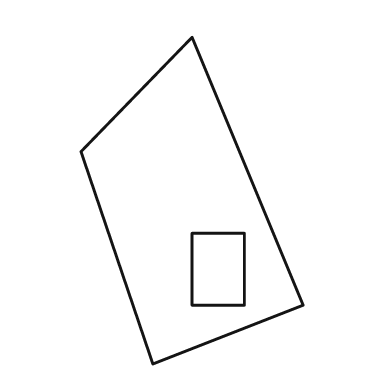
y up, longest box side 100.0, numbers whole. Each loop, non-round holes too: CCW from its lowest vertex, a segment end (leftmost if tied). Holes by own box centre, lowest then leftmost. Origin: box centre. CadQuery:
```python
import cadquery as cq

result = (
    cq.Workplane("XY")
    .moveTo(-12.0, -50.0)
    .lineTo(34.0, -32.0)
    .lineTo(0.0, 50.0)
    .lineTo(-34.0, 15.0)
    .close()
    .moveTo(0.0, -32.0)
    .lineTo(16.0, -32.0)
    .lineTo(16.0, -10.0)
    .lineTo(0.0, -10.0)
    .close()
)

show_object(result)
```